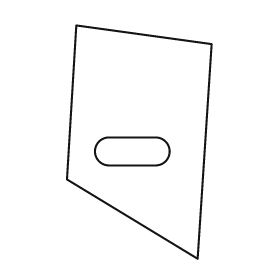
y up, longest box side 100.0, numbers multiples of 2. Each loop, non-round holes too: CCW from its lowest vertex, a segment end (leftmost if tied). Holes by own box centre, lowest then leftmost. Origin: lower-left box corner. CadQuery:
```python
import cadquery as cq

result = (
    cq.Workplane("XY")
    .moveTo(56.0, 0.0)
    .lineTo(62.0, 92.0)
    .lineTo(4.0, 100.0)
    .lineTo(0.0, 34.0)
    .close()
    .moveTo(18.0, 40.0)
    .lineTo(38.0, 40.0)
    .threePointArc((44.0, 46.0), (38.0, 52.0))
    .lineTo(18.0, 52.0)
    .threePointArc((12.0, 46.0), (18.0, 40.0))
    .close()
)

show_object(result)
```